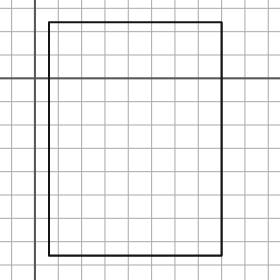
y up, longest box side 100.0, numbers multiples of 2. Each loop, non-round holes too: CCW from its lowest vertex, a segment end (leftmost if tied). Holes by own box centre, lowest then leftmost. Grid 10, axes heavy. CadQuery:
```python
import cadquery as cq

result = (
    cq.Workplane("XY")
    .moveTo(6.0, -76.0)
    .lineTo(80.0, -76.0)
    .lineTo(80.0, 24.0)
    .lineTo(6.0, 24.0)
    .close()
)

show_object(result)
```